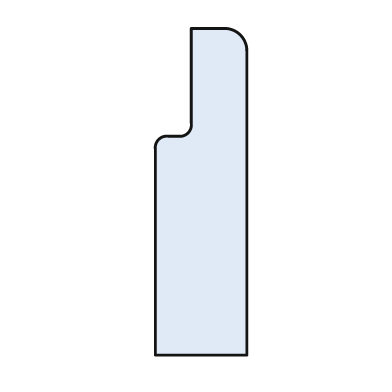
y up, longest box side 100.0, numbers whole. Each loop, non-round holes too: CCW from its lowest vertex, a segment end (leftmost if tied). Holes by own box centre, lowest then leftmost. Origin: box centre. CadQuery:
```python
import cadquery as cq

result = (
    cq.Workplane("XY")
    .moveTo(-14.0, -50.0)
    .lineTo(14.0, -50.0)
    .lineTo(14.0, 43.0)
    .threePointArc((12.0, 48.0), (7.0, 50.0))
    .lineTo(-3.0, 50.0)
    .lineTo(-3.0, 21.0)
    .threePointArc((-4.0, 18.0), (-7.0, 17.0))
    .lineTo(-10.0, 17.0)
    .threePointArc((-13.0, 16.0), (-14.0, 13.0))
    .close()
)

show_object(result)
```